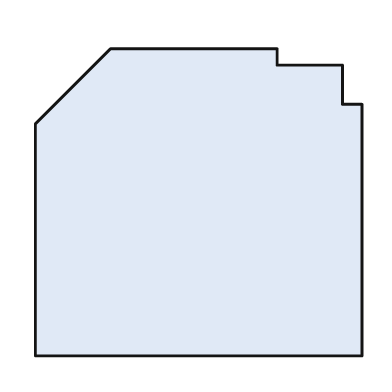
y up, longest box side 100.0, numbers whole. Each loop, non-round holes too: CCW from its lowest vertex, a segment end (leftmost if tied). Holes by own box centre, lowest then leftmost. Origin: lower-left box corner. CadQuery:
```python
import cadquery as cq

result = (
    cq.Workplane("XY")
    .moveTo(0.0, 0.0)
    .lineTo(100.0, 0.0)
    .lineTo(100.0, 77.0)
    .lineTo(94.0, 77.0)
    .lineTo(94.0, 89.0)
    .lineTo(74.0, 89.0)
    .lineTo(74.0, 94.0)
    .lineTo(23.0, 94.0)
    .lineTo(0.0, 71.0)
    .close()
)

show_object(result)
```